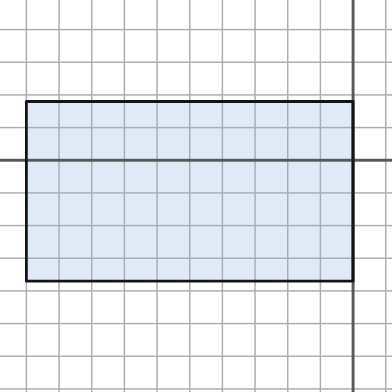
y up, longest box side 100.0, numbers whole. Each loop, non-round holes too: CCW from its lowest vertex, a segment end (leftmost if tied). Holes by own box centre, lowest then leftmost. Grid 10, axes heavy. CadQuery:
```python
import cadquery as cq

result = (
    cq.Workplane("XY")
    .moveTo(-100.0, -37.0)
    .lineTo(0.0, -37.0)
    .lineTo(0.0, 18.0)
    .lineTo(-100.0, 18.0)
    .close()
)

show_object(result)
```